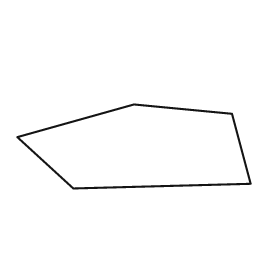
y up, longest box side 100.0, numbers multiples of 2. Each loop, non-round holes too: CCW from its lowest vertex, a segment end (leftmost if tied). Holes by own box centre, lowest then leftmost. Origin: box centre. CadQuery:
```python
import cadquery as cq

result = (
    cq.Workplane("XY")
    .moveTo(-26.0, -18.0)
    .lineTo(50.0, -16.0)
    .lineTo(42.0, 14.0)
    .lineTo(0.0, 18.0)
    .lineTo(-50.0, 4.0)
    .close()
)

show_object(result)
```